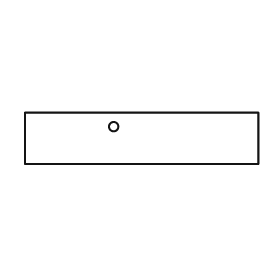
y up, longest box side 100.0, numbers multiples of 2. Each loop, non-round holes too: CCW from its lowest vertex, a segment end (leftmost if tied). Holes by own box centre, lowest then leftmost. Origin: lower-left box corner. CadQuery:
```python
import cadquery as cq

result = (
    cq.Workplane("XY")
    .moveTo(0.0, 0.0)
    .lineTo(100.0, 0.0)
    .lineTo(100.0, 22.0)
    .lineTo(0.0, 22.0)
    .close()
    .moveTo(38.0, 16.0)
    .circle(2.0)
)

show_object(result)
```